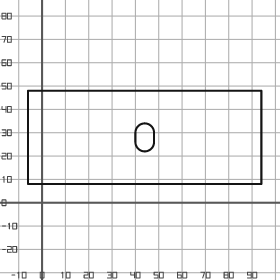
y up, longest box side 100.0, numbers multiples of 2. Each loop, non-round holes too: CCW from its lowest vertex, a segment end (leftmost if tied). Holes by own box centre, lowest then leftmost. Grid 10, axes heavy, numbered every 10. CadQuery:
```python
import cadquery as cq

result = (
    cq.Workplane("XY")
    .moveTo(-6.0, 8.0)
    .lineTo(94.0, 8.0)
    .lineTo(94.0, 48.0)
    .lineTo(-6.0, 48.0)
    .close()
    .moveTo(40.0, 26.0)
    .threePointArc((44.0, 22.0), (48.0, 26.0))
    .lineTo(48.0, 30.0)
    .threePointArc((44.0, 34.0), (40.0, 30.0))
    .close()
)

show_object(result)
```